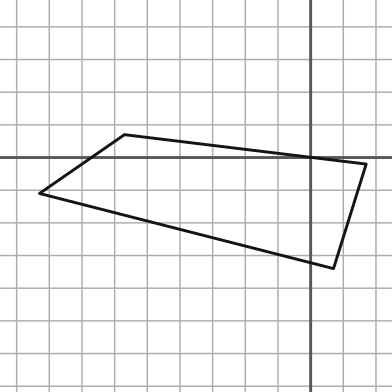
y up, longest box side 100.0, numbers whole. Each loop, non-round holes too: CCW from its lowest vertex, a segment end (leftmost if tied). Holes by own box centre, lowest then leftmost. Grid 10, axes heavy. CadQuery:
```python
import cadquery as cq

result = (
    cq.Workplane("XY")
    .moveTo(7.0, -34.0)
    .lineTo(17.0, -2.0)
    .lineTo(-57.0, 7.0)
    .lineTo(-83.0, -11.0)
    .close()
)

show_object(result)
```